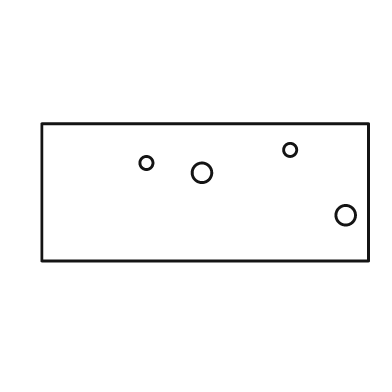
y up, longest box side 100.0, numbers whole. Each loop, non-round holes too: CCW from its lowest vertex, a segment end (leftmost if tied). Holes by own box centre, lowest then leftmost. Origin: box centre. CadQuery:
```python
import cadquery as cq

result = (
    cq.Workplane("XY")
    .moveTo(-50.0, -21.0)
    .lineTo(50.0, -21.0)
    .lineTo(50.0, 21.0)
    .lineTo(-50.0, 21.0)
    .close()
    .moveTo(43.0, -7.0)
    .circle(3.0)
    .moveTo(-1.0, 6.0)
    .circle(3.0)
    .moveTo(-18.0, 9.0)
    .circle(2.0)
    .moveTo(26.0, 13.0)
    .circle(2.0)
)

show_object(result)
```